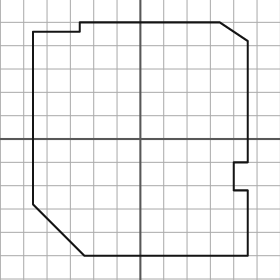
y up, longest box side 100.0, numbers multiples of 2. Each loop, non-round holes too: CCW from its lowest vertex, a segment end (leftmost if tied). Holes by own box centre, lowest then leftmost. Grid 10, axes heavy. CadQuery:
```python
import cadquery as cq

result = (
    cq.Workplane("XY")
    .moveTo(-24.0, -50.0)
    .lineTo(46.0, -50.0)
    .lineTo(46.0, -22.0)
    .lineTo(40.0, -22.0)
    .lineTo(40.0, -10.0)
    .lineTo(46.0, -10.0)
    .lineTo(46.0, 42.0)
    .lineTo(34.0, 50.0)
    .lineTo(-26.0, 50.0)
    .lineTo(-26.0, 46.0)
    .lineTo(-46.0, 46.0)
    .lineTo(-46.0, -28.0)
    .close()
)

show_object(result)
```